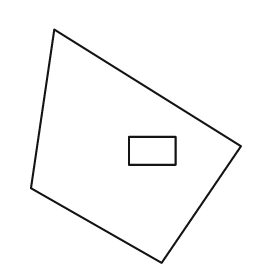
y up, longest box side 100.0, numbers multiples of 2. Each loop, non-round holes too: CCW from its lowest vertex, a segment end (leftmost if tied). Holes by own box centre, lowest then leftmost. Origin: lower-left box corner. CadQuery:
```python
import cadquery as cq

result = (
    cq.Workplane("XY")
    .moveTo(56.0, 0.0)
    .lineTo(90.0, 50.0)
    .lineTo(10.0, 100.0)
    .lineTo(0.0, 32.0)
    .close()
    .moveTo(42.0, 42.0)
    .lineTo(62.0, 42.0)
    .lineTo(62.0, 54.0)
    .lineTo(42.0, 54.0)
    .close()
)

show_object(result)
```